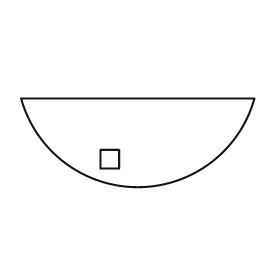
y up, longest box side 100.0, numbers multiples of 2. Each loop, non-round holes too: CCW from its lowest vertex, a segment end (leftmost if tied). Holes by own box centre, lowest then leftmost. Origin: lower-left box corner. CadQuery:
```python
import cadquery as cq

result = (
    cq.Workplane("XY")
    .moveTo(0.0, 38.0)
    .threePointArc((50.0, 0.0), (100.0, 38.0))
    .close()
    .moveTo(34.0, 8.0)
    .lineTo(42.0, 8.0)
    .lineTo(42.0, 16.0)
    .lineTo(34.0, 16.0)
    .close()
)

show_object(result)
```